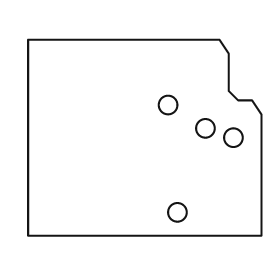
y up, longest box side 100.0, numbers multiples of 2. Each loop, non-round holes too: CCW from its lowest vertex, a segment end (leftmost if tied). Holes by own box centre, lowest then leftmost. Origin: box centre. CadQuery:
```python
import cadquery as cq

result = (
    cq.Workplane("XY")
    .moveTo(-50.0, -42.0)
    .lineTo(50.0, -42.0)
    .lineTo(50.0, 10.0)
    .lineTo(46.0, 16.0)
    .lineTo(40.0, 16.0)
    .lineTo(36.0, 20.0)
    .lineTo(36.0, 36.0)
    .lineTo(32.0, 42.0)
    .lineTo(-50.0, 42.0)
    .close()
    .moveTo(14.0, -32.0)
    .circle(4.0)
    .moveTo(38.0, 0.0)
    .circle(4.0)
    .moveTo(26.0, 4.0)
    .circle(4.0)
    .moveTo(10.0, 14.0)
    .circle(4.0)
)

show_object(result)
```